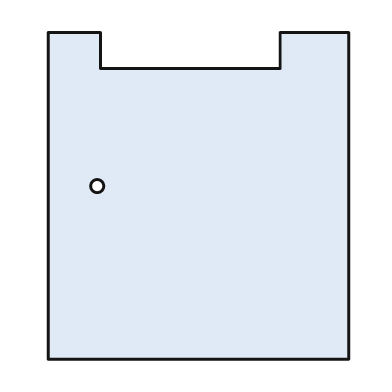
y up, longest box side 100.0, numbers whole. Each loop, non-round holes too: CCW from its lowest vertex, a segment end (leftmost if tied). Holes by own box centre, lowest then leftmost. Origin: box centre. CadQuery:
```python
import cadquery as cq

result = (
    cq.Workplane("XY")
    .moveTo(-46.0, -50.0)
    .lineTo(46.0, -50.0)
    .lineTo(46.0, 50.0)
    .lineTo(25.0, 50.0)
    .lineTo(25.0, 39.0)
    .lineTo(-30.0, 39.0)
    .lineTo(-30.0, 50.0)
    .lineTo(-46.0, 50.0)
    .close()
    .moveTo(-31.0, 3.0)
    .circle(2.0)
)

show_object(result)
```